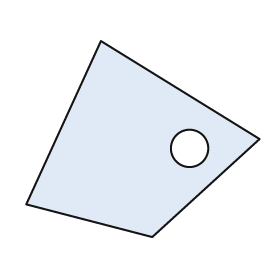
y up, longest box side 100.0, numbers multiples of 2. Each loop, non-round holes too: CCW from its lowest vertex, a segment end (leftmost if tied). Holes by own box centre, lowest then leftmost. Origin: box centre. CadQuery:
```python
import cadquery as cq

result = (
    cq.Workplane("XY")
    .moveTo(4.0, -42.0)
    .lineTo(50.0, 0.0)
    .lineTo(-18.0, 42.0)
    .lineTo(-50.0, -28.0)
    .close()
    .moveTo(20.0, -4.0)
    .circle(8.0)
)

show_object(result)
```